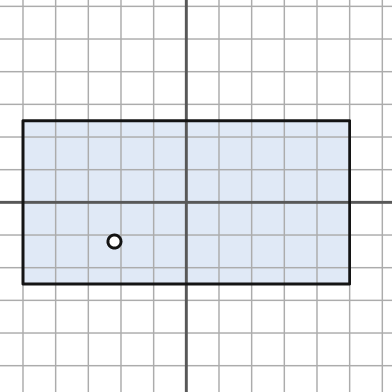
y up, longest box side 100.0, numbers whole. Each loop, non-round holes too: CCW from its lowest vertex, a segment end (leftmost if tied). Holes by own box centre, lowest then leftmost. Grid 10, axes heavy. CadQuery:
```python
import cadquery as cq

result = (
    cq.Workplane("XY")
    .moveTo(-50.0, -25.0)
    .lineTo(50.0, -25.0)
    .lineTo(50.0, 25.0)
    .lineTo(-50.0, 25.0)
    .close()
    .moveTo(-22.0, -12.0)
    .circle(2.0)
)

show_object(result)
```